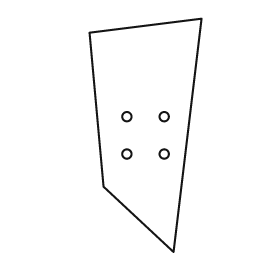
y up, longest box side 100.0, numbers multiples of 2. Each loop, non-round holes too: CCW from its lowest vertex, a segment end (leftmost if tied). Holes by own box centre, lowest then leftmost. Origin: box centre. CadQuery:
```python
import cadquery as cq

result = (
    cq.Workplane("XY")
    .moveTo(12.0, -50.0)
    .lineTo(24.0, 50.0)
    .lineTo(-24.0, 44.0)
    .lineTo(-18.0, -22.0)
    .close()
    .moveTo(-8.0, -8.0)
    .circle(2.0)
    .moveTo(8.0, -8.0)
    .circle(2.0)
    .moveTo(-8.0, 8.0)
    .circle(2.0)
    .moveTo(8.0, 8.0)
    .circle(2.0)
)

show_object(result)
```